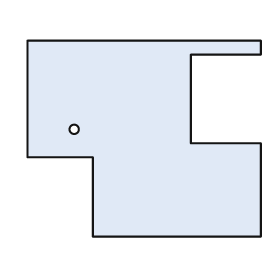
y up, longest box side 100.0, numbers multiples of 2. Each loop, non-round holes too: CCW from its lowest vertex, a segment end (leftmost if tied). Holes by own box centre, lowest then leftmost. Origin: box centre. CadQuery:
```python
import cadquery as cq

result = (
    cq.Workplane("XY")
    .moveTo(-22.0, -42.0)
    .lineTo(50.0, -42.0)
    .lineTo(50.0, -2.0)
    .lineTo(20.0, -2.0)
    .lineTo(20.0, 36.0)
    .lineTo(50.0, 36.0)
    .lineTo(50.0, 42.0)
    .lineTo(-50.0, 42.0)
    .lineTo(-50.0, -8.0)
    .lineTo(-22.0, -8.0)
    .close()
    .moveTo(-30.0, 4.0)
    .circle(2.0)
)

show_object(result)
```